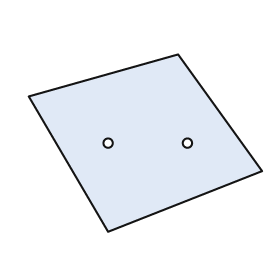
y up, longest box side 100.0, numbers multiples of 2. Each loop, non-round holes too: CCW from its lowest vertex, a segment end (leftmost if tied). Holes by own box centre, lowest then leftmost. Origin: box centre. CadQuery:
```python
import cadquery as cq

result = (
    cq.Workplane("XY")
    .moveTo(-16.0, -38.0)
    .lineTo(50.0, -12.0)
    .lineTo(14.0, 38.0)
    .lineTo(-50.0, 20.0)
    .close()
    .moveTo(-16.0, 0.0)
    .circle(2.0)
    .moveTo(18.0, 0.0)
    .circle(2.0)
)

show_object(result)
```